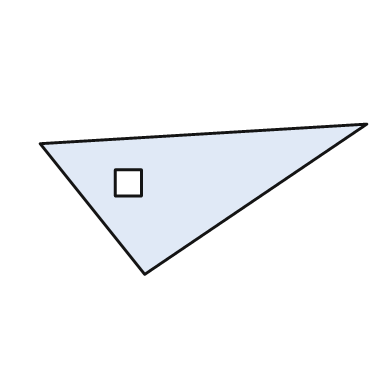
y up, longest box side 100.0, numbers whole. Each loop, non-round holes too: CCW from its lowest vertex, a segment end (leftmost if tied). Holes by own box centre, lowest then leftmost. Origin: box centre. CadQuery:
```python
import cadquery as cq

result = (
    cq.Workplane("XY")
    .moveTo(-18.0, -23.0)
    .lineTo(50.0, 23.0)
    .lineTo(-50.0, 17.0)
    .close()
    .moveTo(-27.0, 1.0)
    .lineTo(-19.0, 1.0)
    .lineTo(-19.0, 9.0)
    .lineTo(-27.0, 9.0)
    .close()
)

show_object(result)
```